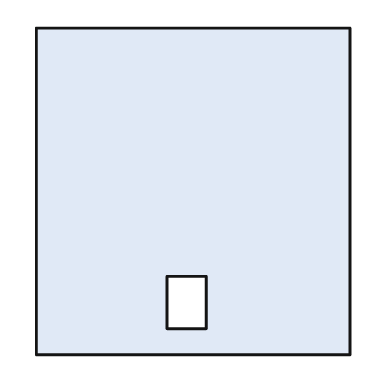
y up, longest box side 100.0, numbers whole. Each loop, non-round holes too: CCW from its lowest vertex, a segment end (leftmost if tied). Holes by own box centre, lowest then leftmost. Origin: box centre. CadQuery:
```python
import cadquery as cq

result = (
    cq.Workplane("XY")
    .moveTo(-48.0, -50.0)
    .lineTo(48.0, -50.0)
    .lineTo(48.0, 50.0)
    .lineTo(-48.0, 50.0)
    .close()
    .moveTo(-8.0, -42.0)
    .lineTo(4.0, -42.0)
    .lineTo(4.0, -26.0)
    .lineTo(-8.0, -26.0)
    .close()
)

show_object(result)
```